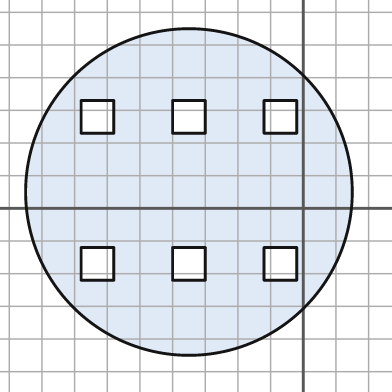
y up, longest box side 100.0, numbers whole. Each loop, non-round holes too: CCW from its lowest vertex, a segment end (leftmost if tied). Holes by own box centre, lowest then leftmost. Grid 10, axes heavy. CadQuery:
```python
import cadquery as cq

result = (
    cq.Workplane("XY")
    .moveTo(-35.0, 5.0)
    .circle(50.0)
    .moveTo(-68.0, -22.0)
    .lineTo(-58.0, -22.0)
    .lineTo(-58.0, -12.0)
    .lineTo(-68.0, -12.0)
    .close()
    .moveTo(-40.0, -22.0)
    .lineTo(-30.0, -22.0)
    .lineTo(-30.0, -12.0)
    .lineTo(-40.0, -12.0)
    .close()
    .moveTo(-12.0, -22.0)
    .lineTo(-2.0, -22.0)
    .lineTo(-2.0, -12.0)
    .lineTo(-12.0, -12.0)
    .close()
    .moveTo(-68.0, 23.0)
    .lineTo(-58.0, 23.0)
    .lineTo(-58.0, 33.0)
    .lineTo(-68.0, 33.0)
    .close()
    .moveTo(-40.0, 23.0)
    .lineTo(-30.0, 23.0)
    .lineTo(-30.0, 33.0)
    .lineTo(-40.0, 33.0)
    .close()
    .moveTo(-12.0, 23.0)
    .lineTo(-2.0, 23.0)
    .lineTo(-2.0, 33.0)
    .lineTo(-12.0, 33.0)
    .close()
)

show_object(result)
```